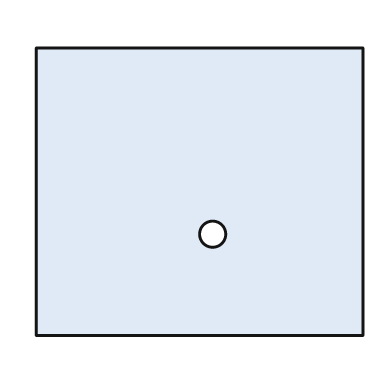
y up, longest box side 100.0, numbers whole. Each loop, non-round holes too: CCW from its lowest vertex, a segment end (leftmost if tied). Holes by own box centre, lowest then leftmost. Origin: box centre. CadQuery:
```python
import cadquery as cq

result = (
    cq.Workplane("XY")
    .moveTo(-50.0, -44.0)
    .lineTo(50.0, -44.0)
    .lineTo(50.0, 44.0)
    .lineTo(-50.0, 44.0)
    .close()
    .moveTo(4.0, -13.0)
    .circle(4.0)
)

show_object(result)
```